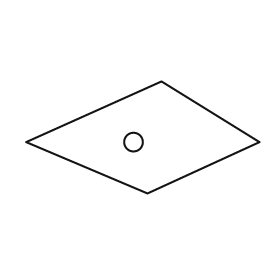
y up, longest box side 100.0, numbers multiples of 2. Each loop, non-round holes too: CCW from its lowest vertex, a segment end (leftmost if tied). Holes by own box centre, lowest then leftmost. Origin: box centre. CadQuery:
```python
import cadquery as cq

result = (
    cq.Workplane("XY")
    .moveTo(2.0, -24.0)
    .lineTo(50.0, -2.0)
    .lineTo(8.0, 24.0)
    .lineTo(-50.0, -2.0)
    .close()
    .moveTo(-4.0, -2.0)
    .circle(4.0)
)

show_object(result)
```